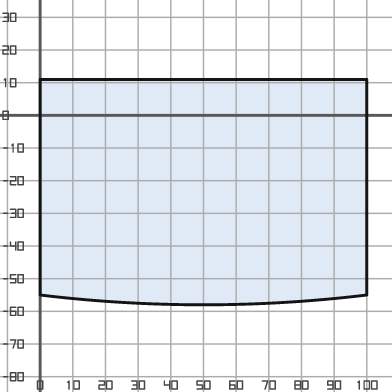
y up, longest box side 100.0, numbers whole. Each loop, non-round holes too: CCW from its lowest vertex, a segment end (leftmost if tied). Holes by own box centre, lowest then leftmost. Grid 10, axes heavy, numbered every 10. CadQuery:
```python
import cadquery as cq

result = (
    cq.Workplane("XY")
    .moveTo(0.0, -55.0)
    .threePointArc((50.0, -58.0), (100.0, -55.0))
    .lineTo(100.0, 11.0)
    .lineTo(0.0, 11.0)
    .close()
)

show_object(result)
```